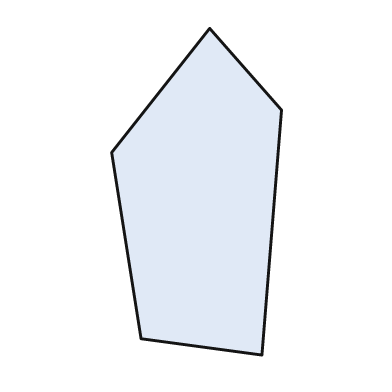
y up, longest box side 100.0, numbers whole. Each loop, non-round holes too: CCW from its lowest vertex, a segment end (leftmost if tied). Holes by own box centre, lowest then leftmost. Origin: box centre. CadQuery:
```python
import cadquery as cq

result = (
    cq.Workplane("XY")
    .moveTo(20.0, -50.0)
    .lineTo(26.0, 25.0)
    .lineTo(4.0, 50.0)
    .lineTo(-26.0, 12.0)
    .lineTo(-17.0, -45.0)
    .close()
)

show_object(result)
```